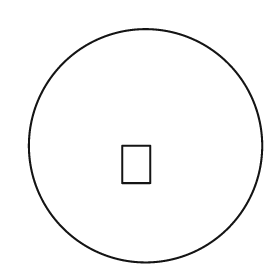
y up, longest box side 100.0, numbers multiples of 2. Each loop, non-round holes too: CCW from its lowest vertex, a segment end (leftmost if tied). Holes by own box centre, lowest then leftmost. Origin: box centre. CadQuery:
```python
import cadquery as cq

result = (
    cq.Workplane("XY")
    .moveTo(0.0, 0.0)
    .circle(50.0)
    .moveTo(-10.0, -16.0)
    .lineTo(2.0, -16.0)
    .lineTo(2.0, 0.0)
    .lineTo(-10.0, 0.0)
    .close()
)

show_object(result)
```